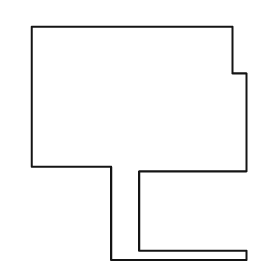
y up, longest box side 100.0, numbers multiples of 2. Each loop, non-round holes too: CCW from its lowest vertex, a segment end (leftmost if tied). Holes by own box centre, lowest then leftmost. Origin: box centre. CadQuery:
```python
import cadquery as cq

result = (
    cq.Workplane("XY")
    .moveTo(-12.0, -50.0)
    .lineTo(46.0, -50.0)
    .lineTo(46.0, -46.0)
    .lineTo(0.0, -46.0)
    .lineTo(0.0, -12.0)
    .lineTo(46.0, -12.0)
    .lineTo(46.0, 30.0)
    .lineTo(40.0, 30.0)
    .lineTo(40.0, 50.0)
    .lineTo(-46.0, 50.0)
    .lineTo(-46.0, -10.0)
    .lineTo(-12.0, -10.0)
    .close()
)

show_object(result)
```